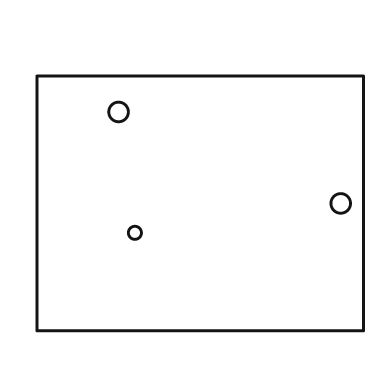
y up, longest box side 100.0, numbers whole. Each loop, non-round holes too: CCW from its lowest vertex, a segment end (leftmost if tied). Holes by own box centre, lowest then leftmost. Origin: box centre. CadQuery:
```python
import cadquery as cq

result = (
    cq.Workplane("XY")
    .moveTo(-50.0, -39.0)
    .lineTo(50.0, -39.0)
    .lineTo(50.0, 39.0)
    .lineTo(-50.0, 39.0)
    .close()
    .moveTo(-20.0, -9.0)
    .circle(2.0)
    .moveTo(43.0, 0.0)
    .circle(3.0)
    .moveTo(-25.0, 28.0)
    .circle(3.0)
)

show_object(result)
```